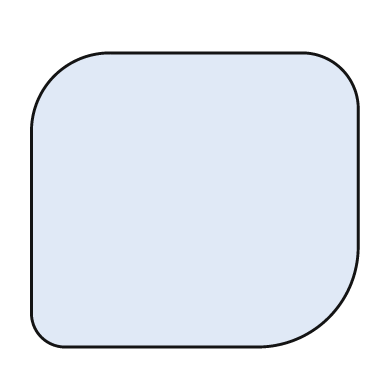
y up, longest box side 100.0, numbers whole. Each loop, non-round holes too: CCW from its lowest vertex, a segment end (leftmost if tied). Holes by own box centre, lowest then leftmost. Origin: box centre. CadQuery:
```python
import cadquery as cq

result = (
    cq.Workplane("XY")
    .moveTo(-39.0, -45.0)
    .lineTo(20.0, -45.0)
    .threePointArc((41.0, -36.0), (50.0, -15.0))
    .lineTo(50.0, 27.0)
    .threePointArc((45.0, 40.0), (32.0, 45.0))
    .lineTo(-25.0, 45.0)
    .threePointArc((-43.0, 38.0), (-50.0, 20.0))
    .lineTo(-50.0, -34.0)
    .threePointArc((-47.0, -42.0), (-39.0, -45.0))
    .close()
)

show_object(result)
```